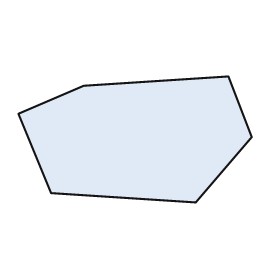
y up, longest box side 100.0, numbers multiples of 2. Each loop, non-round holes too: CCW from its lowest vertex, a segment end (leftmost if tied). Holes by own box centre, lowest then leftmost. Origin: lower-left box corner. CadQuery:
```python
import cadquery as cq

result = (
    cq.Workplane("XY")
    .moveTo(76.0, 0.0)
    .lineTo(100.0, 28.0)
    .lineTo(90.0, 54.0)
    .lineTo(28.0, 50.0)
    .lineTo(0.0, 38.0)
    .lineTo(14.0, 4.0)
    .close()
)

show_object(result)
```